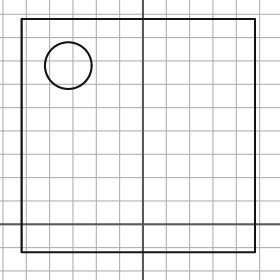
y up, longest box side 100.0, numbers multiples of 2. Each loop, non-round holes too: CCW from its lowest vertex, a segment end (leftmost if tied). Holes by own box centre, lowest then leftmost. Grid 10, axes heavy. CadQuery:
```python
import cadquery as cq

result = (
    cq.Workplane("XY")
    .moveTo(-52.0, -12.0)
    .lineTo(48.0, -12.0)
    .lineTo(48.0, 88.0)
    .lineTo(-52.0, 88.0)
    .close()
    .moveTo(-32.0, 68.0)
    .circle(10.0)
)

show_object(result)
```